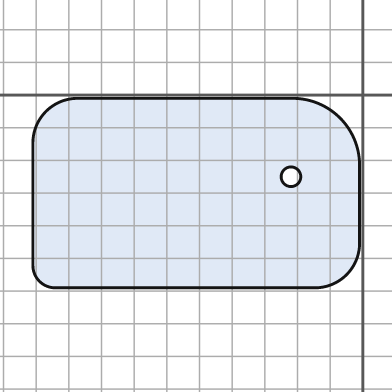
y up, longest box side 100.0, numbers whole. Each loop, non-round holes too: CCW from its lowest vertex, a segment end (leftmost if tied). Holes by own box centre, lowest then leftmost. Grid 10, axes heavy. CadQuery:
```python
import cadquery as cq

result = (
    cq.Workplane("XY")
    .moveTo(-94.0, -59.0)
    .lineTo(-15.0, -59.0)
    .threePointArc((-5.0, -55.0), (-1.0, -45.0))
    .lineTo(-1.0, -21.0)
    .threePointArc((-7.0, -7.0), (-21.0, -1.0))
    .lineTo(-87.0, -1.0)
    .threePointArc((-97.0, -5.0), (-101.0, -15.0))
    .lineTo(-101.0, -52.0)
    .threePointArc((-99.0, -57.0), (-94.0, -59.0))
    .close()
    .moveTo(-22.0, -25.0)
    .circle(3.0)
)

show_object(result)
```